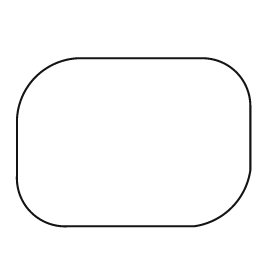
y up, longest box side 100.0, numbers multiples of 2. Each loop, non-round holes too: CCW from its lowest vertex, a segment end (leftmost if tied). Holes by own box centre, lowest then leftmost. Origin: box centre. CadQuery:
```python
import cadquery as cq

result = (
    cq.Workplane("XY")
    .moveTo(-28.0, -36.0)
    .lineTo(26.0, -36.0)
    .threePointArc((42.0, -28.0), (50.0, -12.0))
    .lineTo(50.0, 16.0)
    .threePointArc((44.0, 30.0), (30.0, 36.0))
    .lineTo(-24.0, 36.0)
    .threePointArc((-42.0, 28.0), (-50.0, 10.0))
    .lineTo(-50.0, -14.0)
    .threePointArc((-44.0, -30.0), (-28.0, -36.0))
    .close()
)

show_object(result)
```